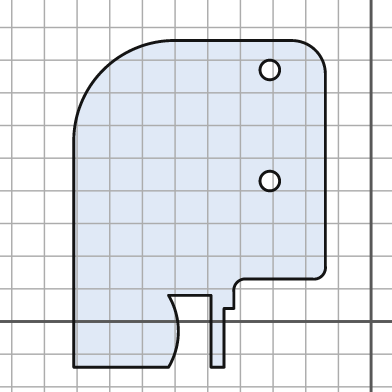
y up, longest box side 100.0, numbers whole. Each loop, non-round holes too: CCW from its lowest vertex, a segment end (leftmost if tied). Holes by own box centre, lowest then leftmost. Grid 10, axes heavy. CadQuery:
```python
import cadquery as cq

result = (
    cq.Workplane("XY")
    .moveTo(-91.0, -14.0)
    .lineTo(-62.0, -14.0)
    .threePointArc((-59.0, -3.0), (-62.0, 8.0))
    .lineTo(-49.0, 8.0)
    .lineTo(-49.0, -14.0)
    .lineTo(-45.0, -14.0)
    .lineTo(-45.0, 4.0)
    .lineTo(-42.0, 4.0)
    .lineTo(-42.0, 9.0)
    .threePointArc((-41.0, 12.0), (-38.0, 13.0))
    .lineTo(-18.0, 13.0)
    .threePointArc((-15.0, 14.0), (-14.0, 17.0))
    .lineTo(-14.0, 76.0)
    .threePointArc((-17.0, 83.0), (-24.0, 86.0))
    .lineTo(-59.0, 86.0)
    .threePointArc((-82.0, 77.0), (-91.0, 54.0))
    .close()
    .moveTo(-31.0, 43.0)
    .circle(3.0)
    .moveTo(-31.0, 77.0)
    .circle(3.0)
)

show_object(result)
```